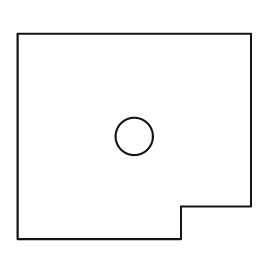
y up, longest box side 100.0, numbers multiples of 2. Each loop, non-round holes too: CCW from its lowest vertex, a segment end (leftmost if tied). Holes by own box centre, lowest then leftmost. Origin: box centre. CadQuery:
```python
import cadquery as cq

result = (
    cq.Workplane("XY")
    .moveTo(-50.0, -44.0)
    .lineTo(20.0, -44.0)
    .lineTo(20.0, -30.0)
    .lineTo(50.0, -30.0)
    .lineTo(50.0, 44.0)
    .lineTo(-50.0, 44.0)
    .close()
    .moveTo(0.0, 0.0)
    .circle(8.0)
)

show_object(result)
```